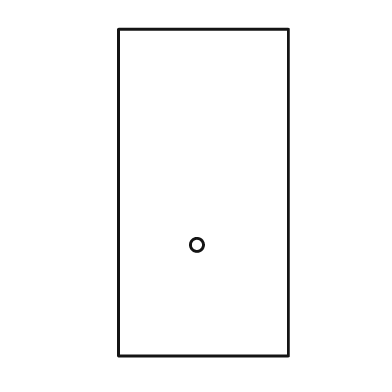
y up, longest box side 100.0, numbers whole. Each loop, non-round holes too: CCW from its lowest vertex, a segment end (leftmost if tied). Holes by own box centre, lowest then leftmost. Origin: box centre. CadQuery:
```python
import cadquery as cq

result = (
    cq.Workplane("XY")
    .moveTo(-26.0, -50.0)
    .lineTo(26.0, -50.0)
    .lineTo(26.0, 50.0)
    .lineTo(-26.0, 50.0)
    .close()
    .moveTo(-2.0, -16.0)
    .circle(2.0)
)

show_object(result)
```